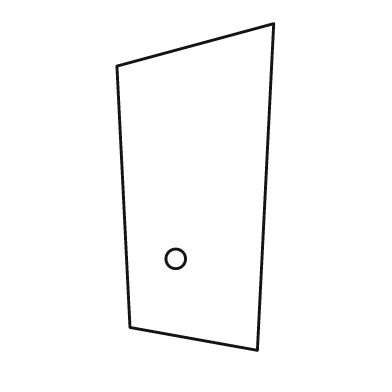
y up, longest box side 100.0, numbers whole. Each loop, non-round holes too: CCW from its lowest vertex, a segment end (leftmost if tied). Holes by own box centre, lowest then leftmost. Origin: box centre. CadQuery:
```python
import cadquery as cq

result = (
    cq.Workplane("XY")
    .moveTo(19.0, -50.0)
    .lineTo(24.0, 50.0)
    .lineTo(-24.0, 37.0)
    .lineTo(-20.0, -43.0)
    .close()
    .moveTo(-6.0, -22.0)
    .circle(3.0)
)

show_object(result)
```